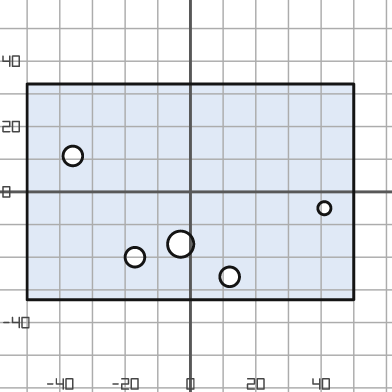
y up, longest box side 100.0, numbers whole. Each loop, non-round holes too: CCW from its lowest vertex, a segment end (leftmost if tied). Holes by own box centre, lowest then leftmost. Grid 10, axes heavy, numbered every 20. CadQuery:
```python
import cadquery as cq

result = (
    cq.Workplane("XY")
    .moveTo(-50.0, -33.0)
    .lineTo(50.0, -33.0)
    .lineTo(50.0, 33.0)
    .lineTo(-50.0, 33.0)
    .close()
    .moveTo(12.0, -26.0)
    .circle(3.0)
    .moveTo(-17.0, -20.0)
    .circle(3.0)
    .moveTo(-3.0, -16.0)
    .circle(4.0)
    .moveTo(41.0, -5.0)
    .circle(2.0)
    .moveTo(-36.0, 11.0)
    .circle(3.0)
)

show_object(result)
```